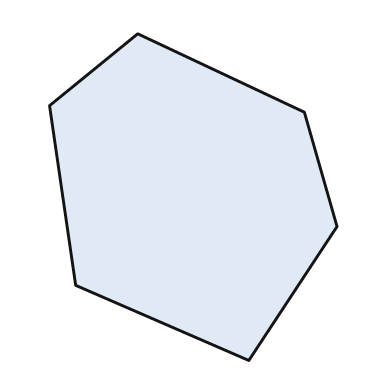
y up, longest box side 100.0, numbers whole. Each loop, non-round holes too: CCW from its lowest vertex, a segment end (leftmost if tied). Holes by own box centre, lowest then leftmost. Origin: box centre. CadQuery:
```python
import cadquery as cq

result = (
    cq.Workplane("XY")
    .moveTo(17.0, -50.0)
    .lineTo(44.0, -9.0)
    .lineTo(34.0, 26.0)
    .lineTo(-17.0, 50.0)
    .lineTo(-44.0, 28.0)
    .lineTo(-36.0, -27.0)
    .close()
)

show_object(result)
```